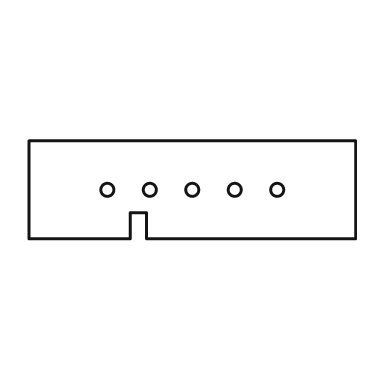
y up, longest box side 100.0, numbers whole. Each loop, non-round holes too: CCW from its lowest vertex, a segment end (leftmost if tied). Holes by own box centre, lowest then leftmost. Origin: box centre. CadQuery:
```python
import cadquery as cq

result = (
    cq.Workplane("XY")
    .moveTo(-50.0, -15.0)
    .lineTo(-19.0, -15.0)
    .lineTo(-19.0, -7.0)
    .lineTo(-14.0, -7.0)
    .lineTo(-14.0, -15.0)
    .lineTo(50.0, -15.0)
    .lineTo(50.0, 15.0)
    .lineTo(-50.0, 15.0)
    .close()
    .moveTo(-26.0, 0.0)
    .circle(2.0)
    .moveTo(-13.0, 0.0)
    .circle(2.0)
    .moveTo(0.0, 0.0)
    .circle(2.0)
    .moveTo(13.0, 0.0)
    .circle(2.0)
    .moveTo(26.0, 0.0)
    .circle(2.0)
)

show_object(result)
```